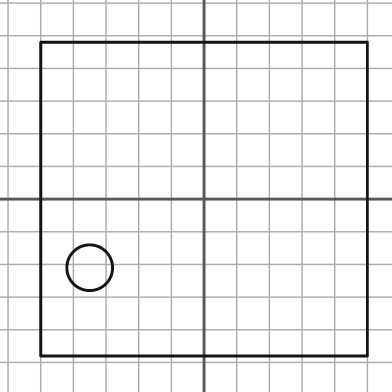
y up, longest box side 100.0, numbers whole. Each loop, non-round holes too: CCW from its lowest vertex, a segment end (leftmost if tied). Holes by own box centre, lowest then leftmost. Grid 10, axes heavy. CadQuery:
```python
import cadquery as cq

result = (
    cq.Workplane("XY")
    .moveTo(-50.0, -48.0)
    .lineTo(50.0, -48.0)
    .lineTo(50.0, 48.0)
    .lineTo(-50.0, 48.0)
    .close()
    .moveTo(-35.0, -21.0)
    .circle(7.0)
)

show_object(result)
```